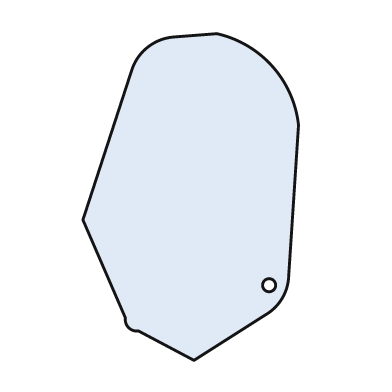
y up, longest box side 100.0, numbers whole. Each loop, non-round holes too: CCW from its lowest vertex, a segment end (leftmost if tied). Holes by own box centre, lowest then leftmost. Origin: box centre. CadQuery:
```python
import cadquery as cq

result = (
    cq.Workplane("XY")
    .moveTo(1.0, -50.0)
    .lineTo(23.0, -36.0)
    .threePointArc((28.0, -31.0), (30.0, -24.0))
    .lineTo(33.0, 22.0)
    .threePointArc((25.0, 40.0), (8.0, 50.0))
    .lineTo(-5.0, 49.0)
    .threePointArc((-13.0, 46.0), (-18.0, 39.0))
    .lineTo(-33.0, -7.0)
    .lineTo(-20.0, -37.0)
    .threePointArc((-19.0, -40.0), (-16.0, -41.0))
    .close()
    .moveTo(24.0, -27.0)
    .circle(2.0)
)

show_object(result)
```